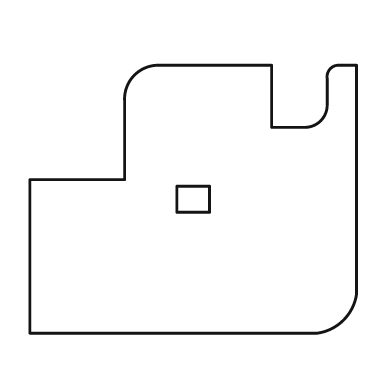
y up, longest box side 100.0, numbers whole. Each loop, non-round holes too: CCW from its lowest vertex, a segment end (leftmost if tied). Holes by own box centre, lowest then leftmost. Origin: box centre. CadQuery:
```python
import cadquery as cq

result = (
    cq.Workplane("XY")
    .moveTo(-50.0, -41.0)
    .lineTo(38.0, -41.0)
    .threePointArc((46.0, -37.0), (50.0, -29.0))
    .lineTo(50.0, 41.0)
    .lineTo(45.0, 41.0)
    .threePointArc((42.0, 40.0), (41.0, 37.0))
    .lineTo(41.0, 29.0)
    .threePointArc((39.0, 24.0), (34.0, 22.0))
    .lineTo(24.0, 22.0)
    .lineTo(24.0, 41.0)
    .lineTo(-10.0, 41.0)
    .threePointArc((-18.0, 38.0), (-21.0, 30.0))
    .lineTo(-21.0, 6.0)
    .lineTo(-50.0, 6.0)
    .close()
    .moveTo(-5.0, -4.0)
    .lineTo(5.0, -4.0)
    .lineTo(5.0, 4.0)
    .lineTo(-5.0, 4.0)
    .close()
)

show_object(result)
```